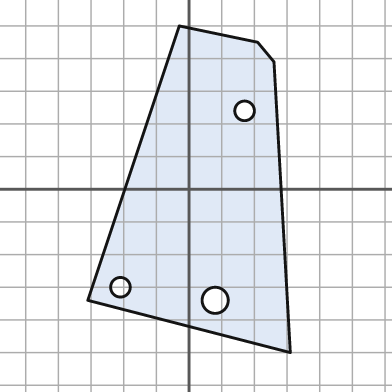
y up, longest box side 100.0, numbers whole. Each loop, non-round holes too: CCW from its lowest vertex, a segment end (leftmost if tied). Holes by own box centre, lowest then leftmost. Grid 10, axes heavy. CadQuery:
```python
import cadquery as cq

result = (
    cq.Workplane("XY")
    .moveTo(31.0, -50.0)
    .lineTo(26.0, 39.0)
    .lineTo(21.0, 45.0)
    .lineTo(-3.0, 50.0)
    .lineTo(-31.0, -34.0)
    .close()
    .moveTo(8.0, -34.0)
    .circle(4.0)
    .moveTo(-21.0, -30.0)
    .circle(3.0)
    .moveTo(17.0, 24.0)
    .circle(3.0)
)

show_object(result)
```